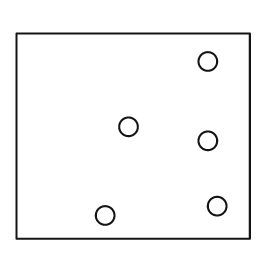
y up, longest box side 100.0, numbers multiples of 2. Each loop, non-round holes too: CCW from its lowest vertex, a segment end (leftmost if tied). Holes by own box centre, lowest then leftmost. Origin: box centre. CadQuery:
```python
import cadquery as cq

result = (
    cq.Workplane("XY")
    .moveTo(-50.0, -44.0)
    .lineTo(50.0, -44.0)
    .lineTo(50.0, 44.0)
    .lineTo(-50.0, 44.0)
    .close()
    .moveTo(-12.0, -34.0)
    .circle(4.0)
    .moveTo(36.0, -30.0)
    .circle(4.0)
    .moveTo(32.0, -2.0)
    .circle(4.0)
    .moveTo(-2.0, 4.0)
    .circle(4.0)
    .moveTo(32.0, 32.0)
    .circle(4.0)
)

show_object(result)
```